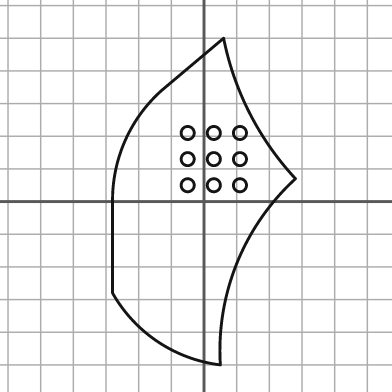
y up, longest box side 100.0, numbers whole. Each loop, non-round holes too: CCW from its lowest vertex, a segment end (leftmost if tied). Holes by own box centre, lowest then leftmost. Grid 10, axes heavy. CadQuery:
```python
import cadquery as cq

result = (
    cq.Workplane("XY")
    .moveTo(5.0, -50.0)
    .threePointArc((10.0, -19.0), (28.0, 7.0))
    .threePointArc((14.0, 27.0), (6.0, 50.0))
    .lineTo(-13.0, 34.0)
    .threePointArc((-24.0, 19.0), (-28.0, 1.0))
    .lineTo(-28.0, -28.0)
    .threePointArc((-14.0, -43.0), (5.0, -50.0))
    .close()
    .moveTo(-5.0, 5.0)
    .circle(2.0)
    .moveTo(3.0, 5.0)
    .circle(2.0)
    .moveTo(11.0, 5.0)
    .circle(2.0)
    .moveTo(-5.0, 13.0)
    .circle(2.0)
    .moveTo(3.0, 13.0)
    .circle(2.0)
    .moveTo(11.0, 13.0)
    .circle(2.0)
    .moveTo(-5.0, 21.0)
    .circle(2.0)
    .moveTo(3.0, 21.0)
    .circle(2.0)
    .moveTo(11.0, 21.0)
    .circle(2.0)
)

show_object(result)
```